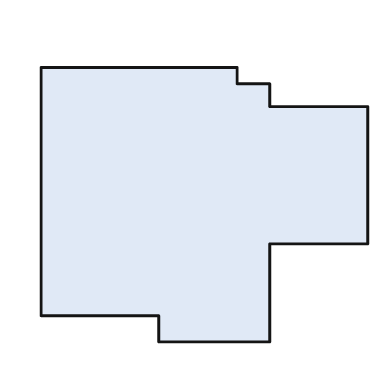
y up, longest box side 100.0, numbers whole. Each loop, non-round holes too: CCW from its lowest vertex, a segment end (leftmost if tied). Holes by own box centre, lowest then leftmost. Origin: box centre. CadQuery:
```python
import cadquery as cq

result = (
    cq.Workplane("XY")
    .moveTo(-14.0, -42.0)
    .lineTo(20.0, -42.0)
    .lineTo(20.0, -12.0)
    .lineTo(50.0, -12.0)
    .lineTo(50.0, 30.0)
    .lineTo(20.0, 30.0)
    .lineTo(20.0, 37.0)
    .lineTo(10.0, 37.0)
    .lineTo(10.0, 42.0)
    .lineTo(-50.0, 42.0)
    .lineTo(-50.0, -34.0)
    .lineTo(-14.0, -34.0)
    .close()
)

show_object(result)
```